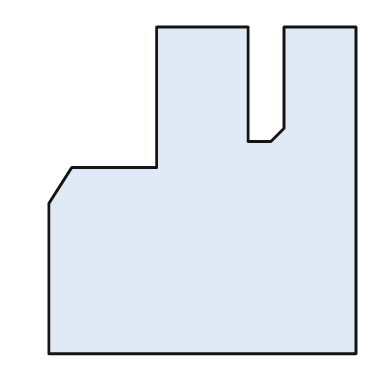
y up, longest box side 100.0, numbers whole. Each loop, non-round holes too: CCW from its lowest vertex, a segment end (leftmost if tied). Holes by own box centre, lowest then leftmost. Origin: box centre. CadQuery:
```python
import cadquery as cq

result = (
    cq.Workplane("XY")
    .moveTo(-47.0, -50.0)
    .lineTo(47.0, -50.0)
    .lineTo(47.0, 50.0)
    .lineTo(25.0, 50.0)
    .lineTo(25.0, 19.0)
    .lineTo(21.0, 15.0)
    .lineTo(14.0, 15.0)
    .lineTo(14.0, 50.0)
    .lineTo(-14.0, 50.0)
    .lineTo(-14.0, 7.0)
    .lineTo(-40.0, 7.0)
    .lineTo(-47.0, -4.0)
    .close()
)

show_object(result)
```